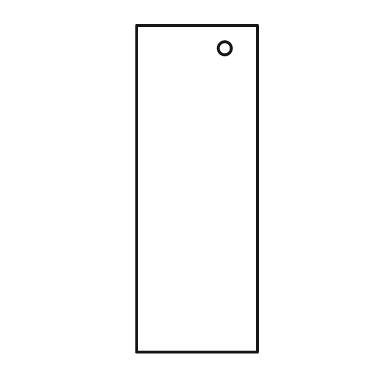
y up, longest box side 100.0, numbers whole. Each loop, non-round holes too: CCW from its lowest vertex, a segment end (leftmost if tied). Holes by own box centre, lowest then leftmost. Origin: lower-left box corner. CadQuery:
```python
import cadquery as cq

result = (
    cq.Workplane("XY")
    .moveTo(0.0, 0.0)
    .lineTo(37.0, 0.0)
    .lineTo(37.0, 100.0)
    .lineTo(0.0, 100.0)
    .close()
    .moveTo(27.0, 93.0)
    .circle(2.0)
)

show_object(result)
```